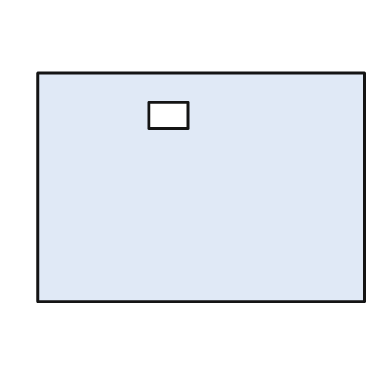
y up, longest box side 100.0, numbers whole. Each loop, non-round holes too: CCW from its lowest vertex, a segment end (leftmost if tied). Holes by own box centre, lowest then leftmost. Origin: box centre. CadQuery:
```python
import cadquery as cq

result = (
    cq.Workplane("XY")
    .moveTo(-50.0, -35.0)
    .lineTo(50.0, -35.0)
    .lineTo(50.0, 35.0)
    .lineTo(-50.0, 35.0)
    .close()
    .moveTo(-16.0, 18.0)
    .lineTo(-4.0, 18.0)
    .lineTo(-4.0, 26.0)
    .lineTo(-16.0, 26.0)
    .close()
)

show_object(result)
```